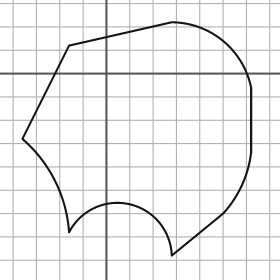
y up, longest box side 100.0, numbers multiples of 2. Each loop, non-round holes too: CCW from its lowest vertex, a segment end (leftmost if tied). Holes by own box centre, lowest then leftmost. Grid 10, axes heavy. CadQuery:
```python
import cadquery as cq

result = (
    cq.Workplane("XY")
    .moveTo(28.0, -78.0)
    .lineTo(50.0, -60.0)
    .threePointArc((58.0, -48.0), (62.0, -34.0))
    .lineTo(62.0, -6.0)
    .threePointArc((50.0, 14.0), (28.0, 22.0))
    .lineTo(-16.0, 12.0)
    .lineTo(-36.0, -28.0)
    .threePointArc((-22.0, -46.0), (-16.0, -68.0))
    .threePointArc((10.0, -56.0), (28.0, -78.0))
    .close()
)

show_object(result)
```